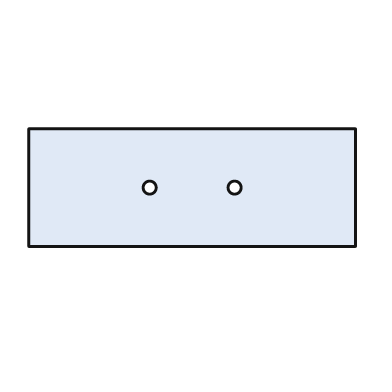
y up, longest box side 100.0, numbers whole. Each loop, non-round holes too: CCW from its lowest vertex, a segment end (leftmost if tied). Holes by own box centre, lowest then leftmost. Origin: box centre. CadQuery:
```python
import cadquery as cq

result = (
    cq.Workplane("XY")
    .moveTo(-50.0, -18.0)
    .lineTo(50.0, -18.0)
    .lineTo(50.0, 18.0)
    .lineTo(-50.0, 18.0)
    .close()
    .moveTo(-13.0, 0.0)
    .circle(2.0)
    .moveTo(13.0, 0.0)
    .circle(2.0)
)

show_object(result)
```